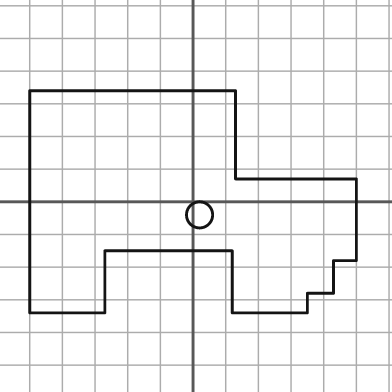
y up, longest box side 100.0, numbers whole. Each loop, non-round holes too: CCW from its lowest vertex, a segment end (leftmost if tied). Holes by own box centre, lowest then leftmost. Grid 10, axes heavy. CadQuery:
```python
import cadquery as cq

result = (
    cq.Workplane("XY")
    .moveTo(-50.0, -34.0)
    .lineTo(-27.0, -34.0)
    .lineTo(-27.0, -15.0)
    .lineTo(12.0, -15.0)
    .lineTo(12.0, -34.0)
    .lineTo(35.0, -34.0)
    .lineTo(35.0, -28.0)
    .lineTo(43.0, -28.0)
    .lineTo(43.0, -18.0)
    .lineTo(50.0, -18.0)
    .lineTo(50.0, 7.0)
    .lineTo(13.0, 7.0)
    .lineTo(13.0, 34.0)
    .lineTo(-50.0, 34.0)
    .close()
    .moveTo(2.0, -4.0)
    .circle(4.0)
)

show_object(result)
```